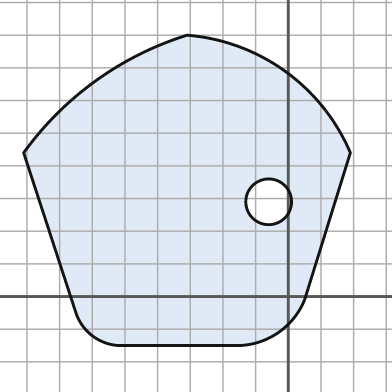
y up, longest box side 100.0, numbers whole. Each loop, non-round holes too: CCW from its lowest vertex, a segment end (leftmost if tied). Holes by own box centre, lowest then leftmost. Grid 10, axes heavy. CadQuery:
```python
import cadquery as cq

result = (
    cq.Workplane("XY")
    .moveTo(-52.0, -15.0)
    .lineTo(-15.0, -15.0)
    .threePointArc((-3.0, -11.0), (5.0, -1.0))
    .lineTo(19.0, 44.0)
    .threePointArc((-1.0, 69.0), (-31.0, 80.0))
    .threePointArc((-59.0, 66.0), (-81.0, 44.0))
    .lineTo(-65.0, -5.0)
    .threePointArc((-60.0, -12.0), (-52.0, -15.0))
    .close()
    .moveTo(-6.0, 29.0)
    .circle(7.0)
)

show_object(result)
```